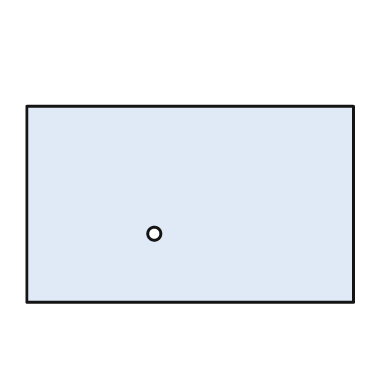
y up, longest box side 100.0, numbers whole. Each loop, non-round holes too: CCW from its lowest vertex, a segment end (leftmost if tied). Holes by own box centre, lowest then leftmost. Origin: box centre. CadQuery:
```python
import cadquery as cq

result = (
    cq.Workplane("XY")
    .moveTo(-50.0, -30.0)
    .lineTo(50.0, -30.0)
    .lineTo(50.0, 30.0)
    .lineTo(-50.0, 30.0)
    .close()
    .moveTo(-11.0, -9.0)
    .circle(2.0)
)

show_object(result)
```